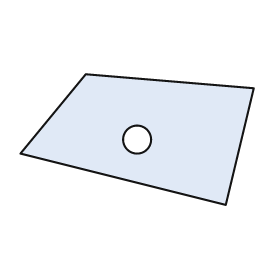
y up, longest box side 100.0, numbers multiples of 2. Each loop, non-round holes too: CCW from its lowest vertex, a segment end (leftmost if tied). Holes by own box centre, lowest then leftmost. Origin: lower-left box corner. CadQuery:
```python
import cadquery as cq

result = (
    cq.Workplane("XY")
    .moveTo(88.0, 0.0)
    .lineTo(100.0, 50.0)
    .lineTo(28.0, 56.0)
    .lineTo(0.0, 22.0)
    .close()
    .moveTo(50.0, 28.0)
    .circle(6.0)
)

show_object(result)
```